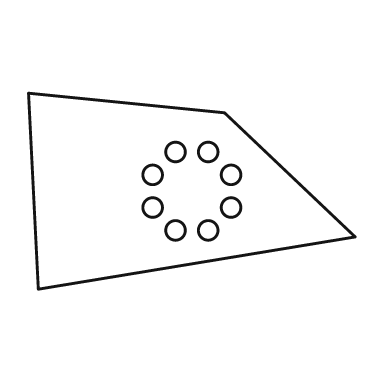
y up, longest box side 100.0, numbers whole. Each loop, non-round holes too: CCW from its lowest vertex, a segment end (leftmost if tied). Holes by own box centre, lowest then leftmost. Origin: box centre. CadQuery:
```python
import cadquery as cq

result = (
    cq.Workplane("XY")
    .moveTo(-47.0, -30.0)
    .lineTo(50.0, -14.0)
    .lineTo(10.0, 24.0)
    .lineTo(-50.0, 30.0)
    .close()
    .moveTo(-5.0, -12.0)
    .circle(3.0)
    .moveTo(5.0, -12.0)
    .circle(3.0)
    .moveTo(-12.0, -5.0)
    .circle(3.0)
    .moveTo(12.0, -5.0)
    .circle(3.0)
    .moveTo(-12.0, 5.0)
    .circle(3.0)
    .moveTo(12.0, 5.0)
    .circle(3.0)
    .moveTo(-5.0, 12.0)
    .circle(3.0)
    .moveTo(5.0, 12.0)
    .circle(3.0)
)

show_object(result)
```